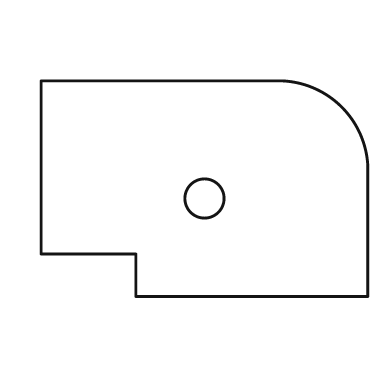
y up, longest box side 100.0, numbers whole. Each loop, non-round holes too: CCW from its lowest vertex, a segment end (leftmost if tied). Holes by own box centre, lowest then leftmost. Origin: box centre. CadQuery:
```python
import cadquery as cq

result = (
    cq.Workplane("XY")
    .moveTo(-21.0, -33.0)
    .lineTo(50.0, -33.0)
    .lineTo(50.0, 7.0)
    .threePointArc((42.0, 25.0), (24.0, 33.0))
    .lineTo(-50.0, 33.0)
    .lineTo(-50.0, -20.0)
    .lineTo(-21.0, -20.0)
    .close()
    .moveTo(0.0, -3.0)
    .circle(6.0)
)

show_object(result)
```